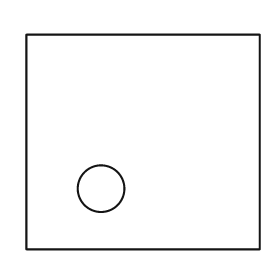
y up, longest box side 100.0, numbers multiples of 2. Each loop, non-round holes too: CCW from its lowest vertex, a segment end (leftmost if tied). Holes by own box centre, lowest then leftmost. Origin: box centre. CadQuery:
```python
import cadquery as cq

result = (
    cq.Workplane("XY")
    .moveTo(-50.0, -46.0)
    .lineTo(50.0, -46.0)
    .lineTo(50.0, 46.0)
    .lineTo(-50.0, 46.0)
    .close()
    .moveTo(-18.0, -20.0)
    .circle(10.0)
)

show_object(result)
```